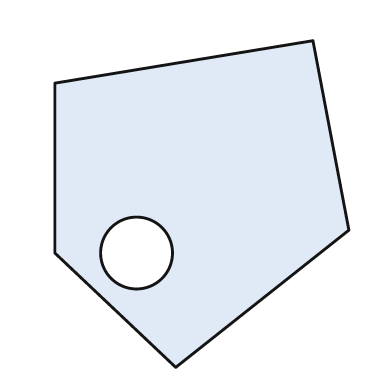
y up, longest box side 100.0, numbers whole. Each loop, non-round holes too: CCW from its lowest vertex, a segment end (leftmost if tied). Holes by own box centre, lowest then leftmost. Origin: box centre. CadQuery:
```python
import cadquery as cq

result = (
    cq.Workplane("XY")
    .moveTo(-8.0, -50.0)
    .lineTo(45.0, -8.0)
    .lineTo(34.0, 50.0)
    .lineTo(-45.0, 37.0)
    .lineTo(-45.0, -15.0)
    .close()
    .moveTo(-20.0, -15.0)
    .circle(11.0)
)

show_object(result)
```